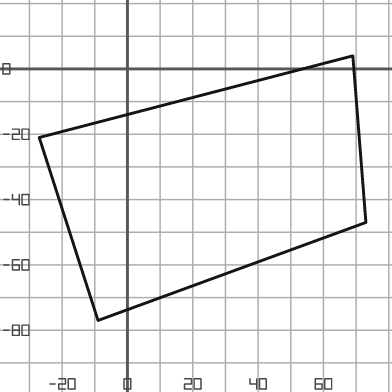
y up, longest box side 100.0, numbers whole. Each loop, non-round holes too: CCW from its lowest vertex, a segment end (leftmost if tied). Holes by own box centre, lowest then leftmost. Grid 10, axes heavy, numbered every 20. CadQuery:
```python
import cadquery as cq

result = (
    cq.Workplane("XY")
    .moveTo(-9.0, -77.0)
    .lineTo(73.0, -47.0)
    .lineTo(69.0, 4.0)
    .lineTo(-27.0, -21.0)
    .close()
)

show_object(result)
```